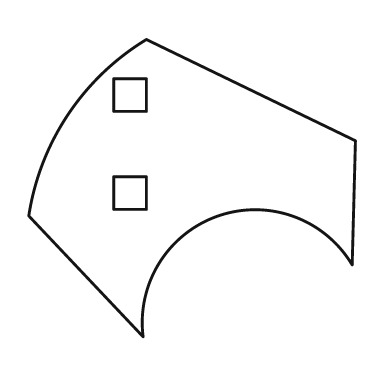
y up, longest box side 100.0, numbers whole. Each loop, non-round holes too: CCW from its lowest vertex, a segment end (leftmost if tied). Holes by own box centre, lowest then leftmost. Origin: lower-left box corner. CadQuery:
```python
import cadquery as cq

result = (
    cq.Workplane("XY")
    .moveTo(35.0, 0.0)
    .threePointArc((58.0, 37.0), (99.0, 22.0))
    .lineTo(100.0, 60.0)
    .lineTo(36.0, 91.0)
    .threePointArc((12.0, 68.0), (0.0, 37.0))
    .close()
    .moveTo(26.0, 39.0)
    .lineTo(36.0, 39.0)
    .lineTo(36.0, 49.0)
    .lineTo(26.0, 49.0)
    .close()
    .moveTo(26.0, 69.0)
    .lineTo(36.0, 69.0)
    .lineTo(36.0, 79.0)
    .lineTo(26.0, 79.0)
    .close()
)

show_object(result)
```